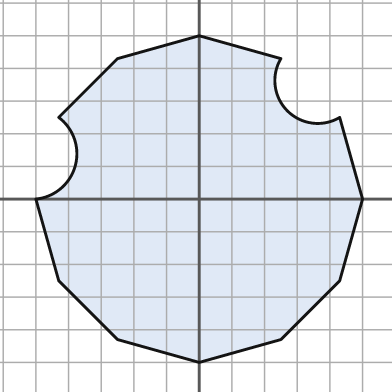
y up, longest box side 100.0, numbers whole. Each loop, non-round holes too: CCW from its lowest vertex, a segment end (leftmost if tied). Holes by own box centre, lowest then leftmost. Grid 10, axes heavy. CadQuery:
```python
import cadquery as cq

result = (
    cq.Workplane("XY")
    .moveTo(0.0, -50.0)
    .lineTo(25.0, -43.0)
    .lineTo(43.0, -25.0)
    .lineTo(50.0, 0.0)
    .lineTo(43.0, 25.0)
    .threePointArc((27.0, 27.0), (25.0, 43.0))
    .lineTo(0.0, 50.0)
    .lineTo(-25.0, 43.0)
    .lineTo(-43.0, 25.0)
    .threePointArc((-38.0, 10.0), (-50.0, 0.0))
    .lineTo(-43.0, -25.0)
    .lineTo(-25.0, -43.0)
    .close()
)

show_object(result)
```